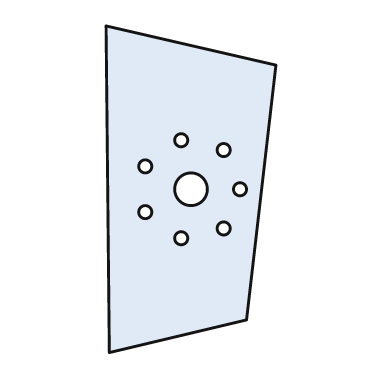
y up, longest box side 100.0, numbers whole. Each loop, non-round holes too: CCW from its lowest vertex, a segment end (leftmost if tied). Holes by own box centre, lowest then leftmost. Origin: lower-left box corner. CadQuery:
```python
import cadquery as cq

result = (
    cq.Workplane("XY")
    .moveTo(1.0, 0.0)
    .lineTo(43.0, 10.0)
    .lineTo(52.0, 88.0)
    .lineTo(0.0, 100.0)
    .close()
    .moveTo(23.0, 35.0)
    .circle(2.0)
    .moveTo(36.0, 38.0)
    .circle(2.0)
    .moveTo(12.0, 43.0)
    .circle(2.0)
    .moveTo(26.0, 50.0)
    .circle(5.0)
    .moveTo(41.0, 50.0)
    .circle(2.0)
    .moveTo(12.0, 57.0)
    .circle(2.0)
    .moveTo(36.0, 62.0)
    .circle(2.0)
    .moveTo(23.0, 65.0)
    .circle(2.0)
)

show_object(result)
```